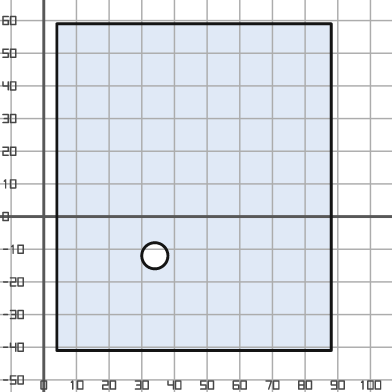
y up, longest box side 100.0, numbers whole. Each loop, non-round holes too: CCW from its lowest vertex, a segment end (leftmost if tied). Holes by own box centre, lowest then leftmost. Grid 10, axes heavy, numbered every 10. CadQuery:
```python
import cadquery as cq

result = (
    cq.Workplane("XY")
    .moveTo(4.0, -41.0)
    .lineTo(88.0, -41.0)
    .lineTo(88.0, 59.0)
    .lineTo(4.0, 59.0)
    .close()
    .moveTo(34.0, -12.0)
    .circle(4.0)
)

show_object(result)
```